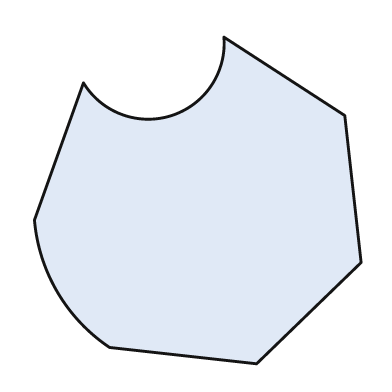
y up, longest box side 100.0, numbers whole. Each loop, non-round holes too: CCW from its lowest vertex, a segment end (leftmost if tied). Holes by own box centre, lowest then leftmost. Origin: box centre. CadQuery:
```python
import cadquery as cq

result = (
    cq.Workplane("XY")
    .moveTo(18.0, -50.0)
    .lineTo(50.0, -19.0)
    .lineTo(45.0, 26.0)
    .lineTo(8.0, 50.0)
    .threePointArc((-8.0, 26.0), (-35.0, 36.0))
    .lineTo(-50.0, -6.0)
    .threePointArc((-43.0, -28.0), (-27.0, -45.0))
    .close()
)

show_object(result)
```